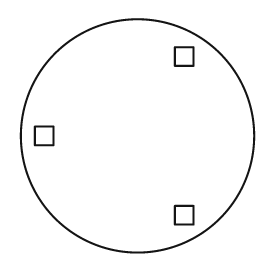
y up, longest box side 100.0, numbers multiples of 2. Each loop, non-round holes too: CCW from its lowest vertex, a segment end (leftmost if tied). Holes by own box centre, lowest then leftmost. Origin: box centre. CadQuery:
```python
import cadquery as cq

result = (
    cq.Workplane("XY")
    .moveTo(0.0, 0.0)
    .circle(50.0)
    .moveTo(16.0, -38.0)
    .lineTo(24.0, -38.0)
    .lineTo(24.0, -30.0)
    .lineTo(16.0, -30.0)
    .close()
    .moveTo(-44.0, -4.0)
    .lineTo(-36.0, -4.0)
    .lineTo(-36.0, 4.0)
    .lineTo(-44.0, 4.0)
    .close()
    .moveTo(16.0, 30.0)
    .lineTo(24.0, 30.0)
    .lineTo(24.0, 38.0)
    .lineTo(16.0, 38.0)
    .close()
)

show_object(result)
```